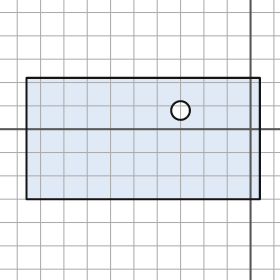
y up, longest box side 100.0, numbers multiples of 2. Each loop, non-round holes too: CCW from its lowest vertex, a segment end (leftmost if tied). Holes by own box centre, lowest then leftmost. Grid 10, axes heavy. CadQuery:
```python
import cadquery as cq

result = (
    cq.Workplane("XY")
    .moveTo(-96.0, -30.0)
    .lineTo(4.0, -30.0)
    .lineTo(4.0, 22.0)
    .lineTo(-96.0, 22.0)
    .close()
    .moveTo(-30.0, 8.0)
    .circle(4.0)
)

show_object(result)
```